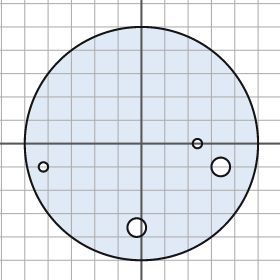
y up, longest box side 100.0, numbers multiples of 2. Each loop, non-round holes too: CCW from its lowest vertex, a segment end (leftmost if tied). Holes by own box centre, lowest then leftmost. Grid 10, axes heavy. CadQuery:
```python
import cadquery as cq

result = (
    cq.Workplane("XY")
    .moveTo(0.0, 0.0)
    .circle(50.0)
    .moveTo(-2.0, -36.0)
    .circle(4.0)
    .moveTo(-42.0, -10.0)
    .circle(2.0)
    .moveTo(34.0, -10.0)
    .circle(4.0)
    .moveTo(24.0, 0.0)
    .circle(2.0)
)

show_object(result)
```